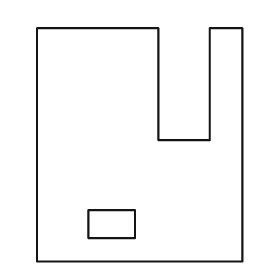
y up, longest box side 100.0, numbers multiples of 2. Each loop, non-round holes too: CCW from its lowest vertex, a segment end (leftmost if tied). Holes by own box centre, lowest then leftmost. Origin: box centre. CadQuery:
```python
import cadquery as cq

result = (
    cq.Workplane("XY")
    .moveTo(-44.0, -50.0)
    .lineTo(44.0, -50.0)
    .lineTo(44.0, 50.0)
    .lineTo(30.0, 50.0)
    .lineTo(30.0, 2.0)
    .lineTo(8.0, 2.0)
    .lineTo(8.0, 50.0)
    .lineTo(-44.0, 50.0)
    .close()
    .moveTo(-22.0, -40.0)
    .lineTo(-2.0, -40.0)
    .lineTo(-2.0, -28.0)
    .lineTo(-22.0, -28.0)
    .close()
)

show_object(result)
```